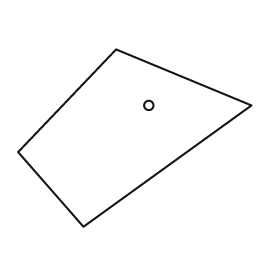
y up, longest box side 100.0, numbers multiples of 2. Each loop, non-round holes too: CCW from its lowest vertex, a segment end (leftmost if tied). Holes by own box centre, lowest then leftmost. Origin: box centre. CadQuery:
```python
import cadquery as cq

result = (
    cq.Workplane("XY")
    .moveTo(-22.0, -38.0)
    .lineTo(50.0, 14.0)
    .lineTo(-8.0, 38.0)
    .lineTo(-50.0, -6.0)
    .close()
    .moveTo(6.0, 14.0)
    .circle(2.0)
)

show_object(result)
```